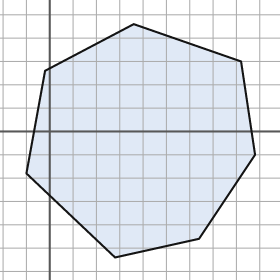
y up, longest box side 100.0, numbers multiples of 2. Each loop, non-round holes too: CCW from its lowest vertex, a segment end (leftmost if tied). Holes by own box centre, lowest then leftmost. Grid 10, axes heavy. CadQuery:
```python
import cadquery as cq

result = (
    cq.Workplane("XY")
    .moveTo(28.0, -54.0)
    .lineTo(64.0, -46.0)
    .lineTo(88.0, -10.0)
    .lineTo(82.0, 30.0)
    .lineTo(36.0, 46.0)
    .lineTo(-2.0, 26.0)
    .lineTo(-10.0, -18.0)
    .close()
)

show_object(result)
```